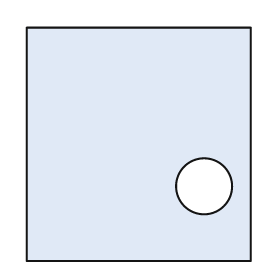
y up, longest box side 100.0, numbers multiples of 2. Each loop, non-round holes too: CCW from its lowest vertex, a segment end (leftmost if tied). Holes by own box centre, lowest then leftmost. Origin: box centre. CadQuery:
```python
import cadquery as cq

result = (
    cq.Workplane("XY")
    .moveTo(-48.0, -50.0)
    .lineTo(48.0, -50.0)
    .lineTo(48.0, 50.0)
    .lineTo(-48.0, 50.0)
    .close()
    .moveTo(28.0, -18.0)
    .circle(12.0)
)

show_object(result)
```